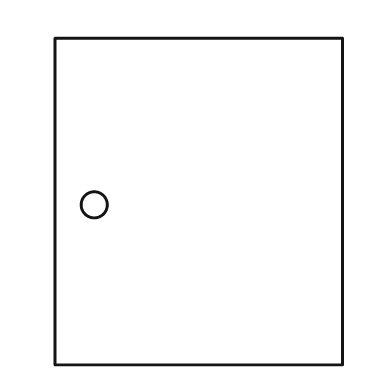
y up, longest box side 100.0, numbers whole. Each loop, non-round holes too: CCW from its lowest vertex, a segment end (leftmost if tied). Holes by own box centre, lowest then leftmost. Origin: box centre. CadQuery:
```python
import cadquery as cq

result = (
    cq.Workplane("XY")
    .moveTo(-44.0, -50.0)
    .lineTo(44.0, -50.0)
    .lineTo(44.0, 50.0)
    .lineTo(-44.0, 50.0)
    .close()
    .moveTo(-32.0, -1.0)
    .circle(4.0)
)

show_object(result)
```